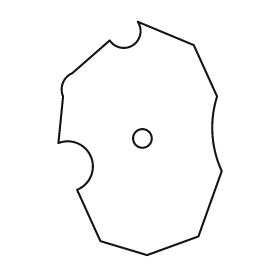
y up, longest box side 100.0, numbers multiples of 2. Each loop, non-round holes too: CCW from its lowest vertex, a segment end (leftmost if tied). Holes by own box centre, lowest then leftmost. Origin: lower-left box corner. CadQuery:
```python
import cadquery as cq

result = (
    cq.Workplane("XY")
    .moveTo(38.0, 0.0)
    .lineTo(60.0, 8.0)
    .lineTo(70.0, 36.0)
    .threePointArc((66.0, 52.0), (68.0, 68.0))
    .lineTo(58.0, 90.0)
    .lineTo(34.0, 100.0)
    .threePointArc((32.0, 90.0), (22.0, 92.0))
    .lineTo(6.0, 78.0)
    .threePointArc((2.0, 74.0), (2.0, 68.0))
    .lineTo(0.0, 48.0)
    .threePointArc((14.0, 42.0), (8.0, 28.0))
    .lineTo(18.0, 6.0)
    .close()
    .moveTo(36.0, 50.0)
    .circle(4.0)
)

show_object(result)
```